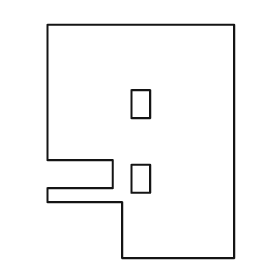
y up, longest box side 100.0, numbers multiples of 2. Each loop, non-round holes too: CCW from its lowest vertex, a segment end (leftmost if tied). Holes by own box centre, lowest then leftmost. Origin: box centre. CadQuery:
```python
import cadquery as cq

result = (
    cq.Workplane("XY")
    .moveTo(-8.0, -50.0)
    .lineTo(40.0, -50.0)
    .lineTo(40.0, 50.0)
    .lineTo(-40.0, 50.0)
    .lineTo(-40.0, -8.0)
    .lineTo(-12.0, -8.0)
    .lineTo(-12.0, -20.0)
    .lineTo(-40.0, -20.0)
    .lineTo(-40.0, -26.0)
    .lineTo(-8.0, -26.0)
    .close()
    .moveTo(-4.0, -22.0)
    .lineTo(4.0, -22.0)
    .lineTo(4.0, -10.0)
    .lineTo(-4.0, -10.0)
    .close()
    .moveTo(-4.0, 10.0)
    .lineTo(4.0, 10.0)
    .lineTo(4.0, 22.0)
    .lineTo(-4.0, 22.0)
    .close()
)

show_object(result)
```